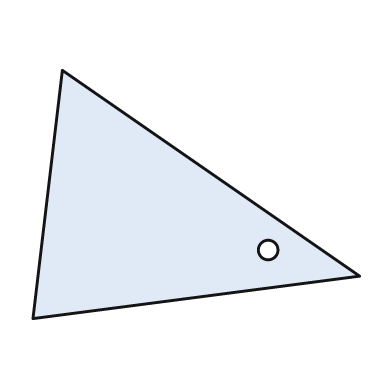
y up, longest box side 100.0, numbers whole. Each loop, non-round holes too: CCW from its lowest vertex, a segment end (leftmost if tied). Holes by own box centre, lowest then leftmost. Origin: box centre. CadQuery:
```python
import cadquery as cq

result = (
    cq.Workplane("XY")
    .moveTo(-50.0, -38.0)
    .lineTo(50.0, -25.0)
    .lineTo(-41.0, 38.0)
    .close()
    .moveTo(22.0, -17.0)
    .circle(3.0)
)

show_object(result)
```